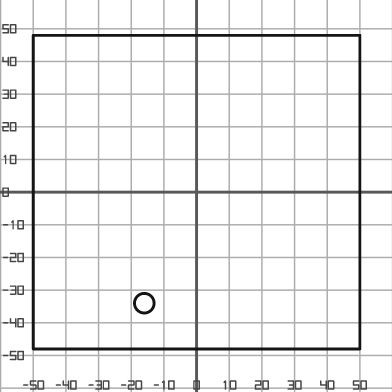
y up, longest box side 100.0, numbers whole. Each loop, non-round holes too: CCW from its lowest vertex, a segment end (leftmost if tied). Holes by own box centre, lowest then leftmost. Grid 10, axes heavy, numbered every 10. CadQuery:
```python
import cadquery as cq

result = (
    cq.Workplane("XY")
    .moveTo(-50.0, -48.0)
    .lineTo(50.0, -48.0)
    .lineTo(50.0, 48.0)
    .lineTo(-50.0, 48.0)
    .close()
    .moveTo(-16.0, -34.0)
    .circle(3.0)
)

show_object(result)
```